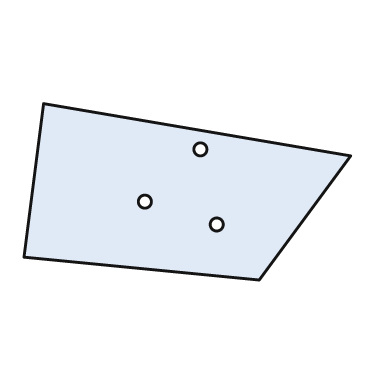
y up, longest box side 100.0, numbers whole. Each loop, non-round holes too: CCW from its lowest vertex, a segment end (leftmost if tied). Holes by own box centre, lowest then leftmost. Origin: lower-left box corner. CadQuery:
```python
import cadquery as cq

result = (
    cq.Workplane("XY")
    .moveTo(72.0, 0.0)
    .lineTo(100.0, 38.0)
    .lineTo(6.0, 54.0)
    .lineTo(0.0, 7.0)
    .close()
    .moveTo(59.0, 17.0)
    .circle(2.0)
    .moveTo(37.0, 24.0)
    .circle(2.0)
    .moveTo(54.0, 40.0)
    .circle(2.0)
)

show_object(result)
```